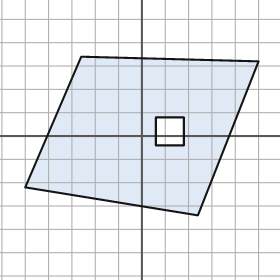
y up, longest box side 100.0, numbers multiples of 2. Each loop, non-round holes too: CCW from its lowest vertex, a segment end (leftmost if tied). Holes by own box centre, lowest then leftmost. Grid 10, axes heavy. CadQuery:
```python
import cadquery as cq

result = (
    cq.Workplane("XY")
    .moveTo(24.0, -34.0)
    .lineTo(50.0, 32.0)
    .lineTo(-26.0, 34.0)
    .lineTo(-50.0, -22.0)
    .close()
    .moveTo(6.0, -4.0)
    .lineTo(18.0, -4.0)
    .lineTo(18.0, 8.0)
    .lineTo(6.0, 8.0)
    .close()
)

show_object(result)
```